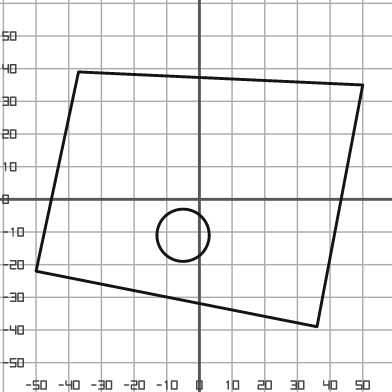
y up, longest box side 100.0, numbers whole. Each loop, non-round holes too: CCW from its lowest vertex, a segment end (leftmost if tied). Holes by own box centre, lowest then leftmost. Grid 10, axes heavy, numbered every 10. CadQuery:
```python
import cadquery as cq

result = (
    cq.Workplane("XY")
    .moveTo(36.0, -39.0)
    .lineTo(50.0, 35.0)
    .lineTo(-37.0, 39.0)
    .lineTo(-50.0, -22.0)
    .close()
    .moveTo(-5.0, -11.0)
    .circle(8.0)
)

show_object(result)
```